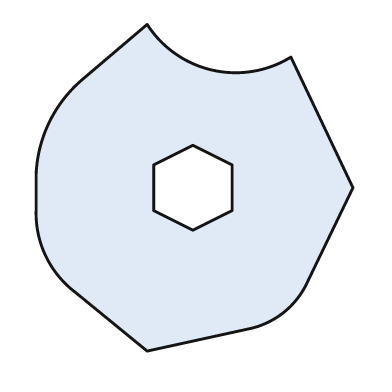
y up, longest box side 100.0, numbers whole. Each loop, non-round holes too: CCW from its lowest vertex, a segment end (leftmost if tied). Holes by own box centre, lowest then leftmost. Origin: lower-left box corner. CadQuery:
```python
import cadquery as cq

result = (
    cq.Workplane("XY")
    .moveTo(34.0, 0.0)
    .lineTo(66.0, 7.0)
    .threePointArc((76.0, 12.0), (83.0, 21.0))
    .lineTo(97.0, 50.0)
    .lineTo(78.0, 90.0)
    .threePointArc((54.0, 86.0), (34.0, 100.0))
    .lineTo(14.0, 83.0)
    .threePointArc((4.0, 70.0), (0.0, 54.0))
    .lineTo(0.0, 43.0)
    .threePointArc((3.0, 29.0), (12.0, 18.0))
    .close()
    .moveTo(48.0, 37.0)
    .lineTo(60.0, 43.0)
    .lineTo(60.0, 57.0)
    .lineTo(48.0, 63.0)
    .lineTo(36.0, 57.0)
    .lineTo(36.0, 43.0)
    .close()
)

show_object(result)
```